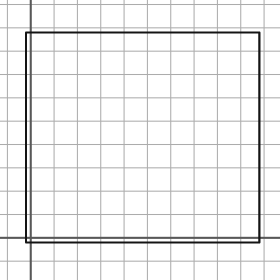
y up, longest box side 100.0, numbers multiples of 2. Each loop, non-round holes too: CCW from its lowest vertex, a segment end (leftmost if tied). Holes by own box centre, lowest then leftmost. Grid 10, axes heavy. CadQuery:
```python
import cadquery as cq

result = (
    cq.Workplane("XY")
    .moveTo(-2.0, -2.0)
    .lineTo(98.0, -2.0)
    .lineTo(98.0, 88.0)
    .lineTo(-2.0, 88.0)
    .close()
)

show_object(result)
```